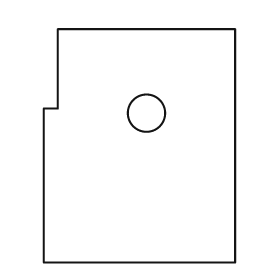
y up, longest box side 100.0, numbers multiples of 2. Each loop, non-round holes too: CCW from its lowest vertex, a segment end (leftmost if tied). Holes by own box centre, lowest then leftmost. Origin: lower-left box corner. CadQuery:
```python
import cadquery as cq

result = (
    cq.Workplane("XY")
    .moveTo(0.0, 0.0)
    .lineTo(82.0, 0.0)
    .lineTo(82.0, 100.0)
    .lineTo(6.0, 100.0)
    .lineTo(6.0, 66.0)
    .lineTo(0.0, 66.0)
    .close()
    .moveTo(44.0, 64.0)
    .circle(8.0)
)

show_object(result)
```